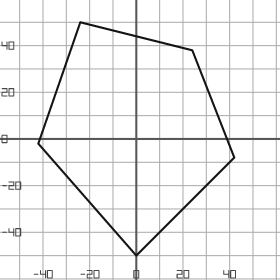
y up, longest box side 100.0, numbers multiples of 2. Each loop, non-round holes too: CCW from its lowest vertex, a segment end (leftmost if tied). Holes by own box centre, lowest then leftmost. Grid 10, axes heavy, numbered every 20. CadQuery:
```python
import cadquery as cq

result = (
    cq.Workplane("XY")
    .moveTo(0.0, -50.0)
    .lineTo(42.0, -8.0)
    .lineTo(24.0, 38.0)
    .lineTo(-24.0, 50.0)
    .lineTo(-42.0, -2.0)
    .close()
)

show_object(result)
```